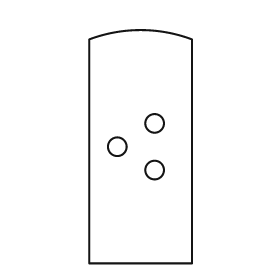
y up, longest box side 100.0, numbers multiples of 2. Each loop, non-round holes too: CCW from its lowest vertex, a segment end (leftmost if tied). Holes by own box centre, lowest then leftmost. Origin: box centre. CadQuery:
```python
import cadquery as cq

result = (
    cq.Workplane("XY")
    .moveTo(-22.0, -50.0)
    .lineTo(22.0, -50.0)
    .lineTo(22.0, 46.0)
    .threePointArc((0.0, 50.0), (-22.0, 46.0))
    .close()
    .moveTo(6.0, -10.0)
    .circle(4.0)
    .moveTo(-10.0, 0.0)
    .circle(4.0)
    .moveTo(6.0, 10.0)
    .circle(4.0)
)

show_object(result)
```